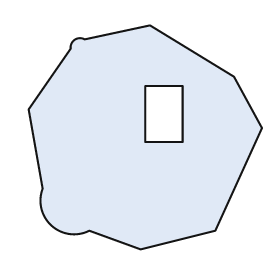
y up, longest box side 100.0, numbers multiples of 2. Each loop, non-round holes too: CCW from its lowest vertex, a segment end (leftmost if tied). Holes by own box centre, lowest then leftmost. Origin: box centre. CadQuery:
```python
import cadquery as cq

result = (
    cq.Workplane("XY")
    .moveTo(-2.0, -48.0)
    .lineTo(30.0, -40.0)
    .lineTo(50.0, 4.0)
    .lineTo(38.0, 26.0)
    .lineTo(2.0, 48.0)
    .lineTo(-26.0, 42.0)
    .threePointArc((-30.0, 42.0), (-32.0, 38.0))
    .lineTo(-50.0, 12.0)
    .lineTo(-44.0, -22.0)
    .threePointArc((-40.0, -38.0), (-24.0, -40.0))
    .close()
    .moveTo(0.0, -2.0)
    .lineTo(16.0, -2.0)
    .lineTo(16.0, 22.0)
    .lineTo(0.0, 22.0)
    .close()
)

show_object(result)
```